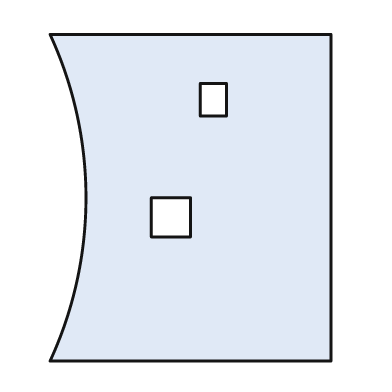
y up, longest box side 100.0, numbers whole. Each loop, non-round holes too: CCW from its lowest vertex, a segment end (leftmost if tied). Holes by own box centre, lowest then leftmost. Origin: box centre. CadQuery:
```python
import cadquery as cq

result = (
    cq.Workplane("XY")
    .moveTo(-43.0, -50.0)
    .lineTo(43.0, -50.0)
    .lineTo(43.0, 50.0)
    .lineTo(-43.0, 50.0)
    .threePointArc((-32.0, 0.0), (-43.0, -50.0))
    .close()
    .moveTo(-12.0, -12.0)
    .lineTo(0.0, -12.0)
    .lineTo(0.0, 0.0)
    .lineTo(-12.0, 0.0)
    .close()
    .moveTo(3.0, 25.0)
    .lineTo(11.0, 25.0)
    .lineTo(11.0, 35.0)
    .lineTo(3.0, 35.0)
    .close()
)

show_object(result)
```